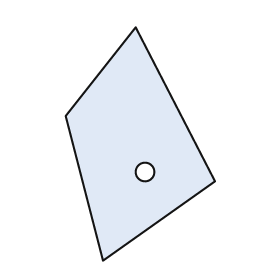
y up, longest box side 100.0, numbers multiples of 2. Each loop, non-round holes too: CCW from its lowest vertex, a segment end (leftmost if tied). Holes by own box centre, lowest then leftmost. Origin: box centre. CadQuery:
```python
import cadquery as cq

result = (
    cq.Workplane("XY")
    .moveTo(-16.0, -50.0)
    .lineTo(32.0, -16.0)
    .lineTo(-2.0, 50.0)
    .lineTo(-32.0, 12.0)
    .close()
    .moveTo(2.0, -12.0)
    .circle(4.0)
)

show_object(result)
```